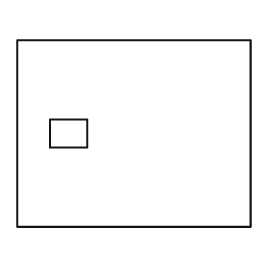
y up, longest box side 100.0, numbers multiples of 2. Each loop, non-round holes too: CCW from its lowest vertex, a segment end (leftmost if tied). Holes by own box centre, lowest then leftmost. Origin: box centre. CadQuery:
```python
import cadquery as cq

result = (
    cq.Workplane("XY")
    .moveTo(-50.0, -40.0)
    .lineTo(50.0, -40.0)
    .lineTo(50.0, 40.0)
    .lineTo(-50.0, 40.0)
    .close()
    .moveTo(-36.0, -6.0)
    .lineTo(-20.0, -6.0)
    .lineTo(-20.0, 6.0)
    .lineTo(-36.0, 6.0)
    .close()
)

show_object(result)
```